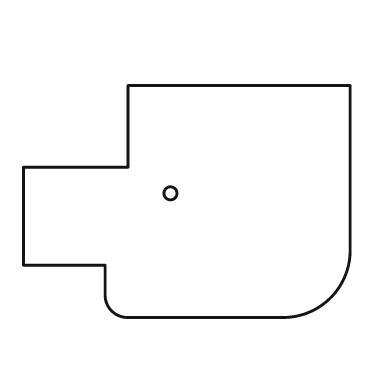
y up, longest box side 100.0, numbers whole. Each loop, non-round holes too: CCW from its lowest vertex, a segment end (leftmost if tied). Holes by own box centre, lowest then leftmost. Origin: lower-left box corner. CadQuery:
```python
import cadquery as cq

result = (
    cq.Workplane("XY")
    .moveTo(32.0, 0.0)
    .lineTo(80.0, 0.0)
    .threePointArc((94.0, 6.0), (100.0, 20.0))
    .lineTo(100.0, 71.0)
    .lineTo(32.0, 71.0)
    .lineTo(32.0, 46.0)
    .lineTo(0.0, 46.0)
    .lineTo(0.0, 16.0)
    .lineTo(25.0, 16.0)
    .lineTo(25.0, 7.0)
    .threePointArc((27.0, 2.0), (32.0, 0.0))
    .close()
    .moveTo(45.0, 38.0)
    .circle(2.0)
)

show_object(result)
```